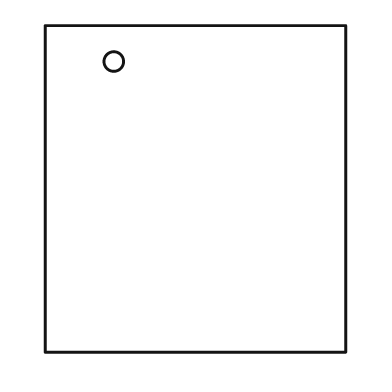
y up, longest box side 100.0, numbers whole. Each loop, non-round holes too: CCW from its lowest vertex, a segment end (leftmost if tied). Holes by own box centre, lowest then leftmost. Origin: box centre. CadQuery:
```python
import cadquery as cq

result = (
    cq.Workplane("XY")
    .moveTo(-46.0, -50.0)
    .lineTo(46.0, -50.0)
    .lineTo(46.0, 50.0)
    .lineTo(-46.0, 50.0)
    .close()
    .moveTo(-25.0, 39.0)
    .circle(3.0)
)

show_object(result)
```